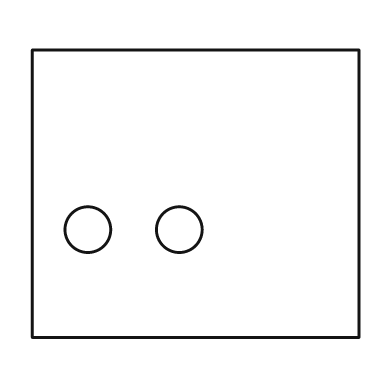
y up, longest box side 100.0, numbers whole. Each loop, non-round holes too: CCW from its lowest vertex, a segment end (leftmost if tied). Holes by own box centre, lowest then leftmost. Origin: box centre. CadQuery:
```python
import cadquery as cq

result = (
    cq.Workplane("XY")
    .moveTo(-50.0, -44.0)
    .lineTo(50.0, -44.0)
    .lineTo(50.0, 44.0)
    .lineTo(-50.0, 44.0)
    .close()
    .moveTo(-33.0, -11.0)
    .circle(7.0)
    .moveTo(-5.0, -11.0)
    .circle(7.0)
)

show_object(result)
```